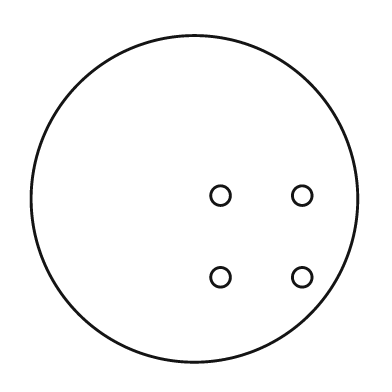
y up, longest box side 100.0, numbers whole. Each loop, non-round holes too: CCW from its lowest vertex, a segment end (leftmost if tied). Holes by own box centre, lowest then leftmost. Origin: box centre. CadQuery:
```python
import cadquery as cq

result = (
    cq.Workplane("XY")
    .moveTo(0.0, 0.0)
    .circle(50.0)
    .moveTo(8.0, -24.0)
    .circle(3.0)
    .moveTo(33.0, -24.0)
    .circle(3.0)
    .moveTo(8.0, 1.0)
    .circle(3.0)
    .moveTo(33.0, 1.0)
    .circle(3.0)
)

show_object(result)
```